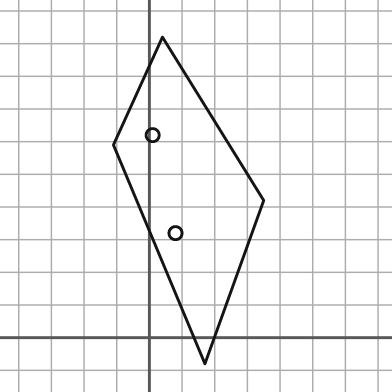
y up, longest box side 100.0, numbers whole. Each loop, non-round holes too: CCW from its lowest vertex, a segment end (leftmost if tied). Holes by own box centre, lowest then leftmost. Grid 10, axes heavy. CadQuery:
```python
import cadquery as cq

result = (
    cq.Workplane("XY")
    .moveTo(17.0, -8.0)
    .lineTo(35.0, 42.0)
    .lineTo(4.0, 92.0)
    .lineTo(-11.0, 59.0)
    .close()
    .moveTo(8.0, 32.0)
    .circle(2.0)
    .moveTo(1.0, 62.0)
    .circle(2.0)
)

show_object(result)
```